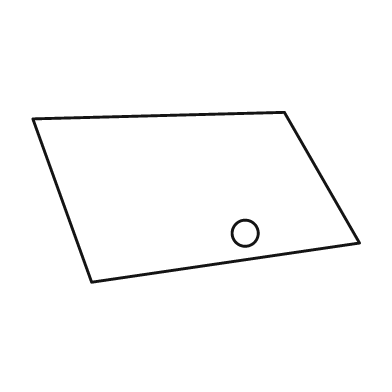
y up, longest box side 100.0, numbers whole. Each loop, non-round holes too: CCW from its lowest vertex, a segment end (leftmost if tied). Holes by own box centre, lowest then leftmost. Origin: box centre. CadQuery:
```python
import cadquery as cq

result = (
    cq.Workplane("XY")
    .moveTo(-32.0, -26.0)
    .lineTo(50.0, -14.0)
    .lineTo(27.0, 26.0)
    .lineTo(-50.0, 24.0)
    .close()
    .moveTo(15.0, -11.0)
    .circle(4.0)
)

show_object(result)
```